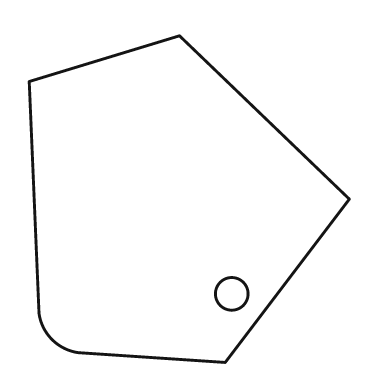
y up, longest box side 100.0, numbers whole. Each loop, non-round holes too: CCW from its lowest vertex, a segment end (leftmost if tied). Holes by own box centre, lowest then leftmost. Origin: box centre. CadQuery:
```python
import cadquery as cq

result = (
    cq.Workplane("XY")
    .moveTo(11.0, -50.0)
    .lineTo(49.0, 0.0)
    .lineTo(-3.0, 50.0)
    .lineTo(-49.0, 36.0)
    .lineTo(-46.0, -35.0)
    .threePointArc((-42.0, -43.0), (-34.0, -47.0))
    .close()
    .moveTo(13.0, -29.0)
    .circle(5.0)
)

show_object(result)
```